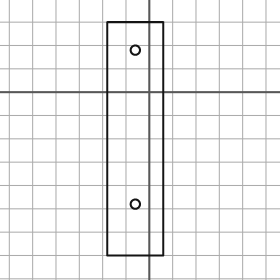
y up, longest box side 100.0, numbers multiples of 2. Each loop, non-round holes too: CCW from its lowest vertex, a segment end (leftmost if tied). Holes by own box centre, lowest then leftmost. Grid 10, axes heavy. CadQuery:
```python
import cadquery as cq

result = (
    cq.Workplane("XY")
    .moveTo(-18.0, -70.0)
    .lineTo(6.0, -70.0)
    .lineTo(6.0, 30.0)
    .lineTo(-18.0, 30.0)
    .close()
    .moveTo(-6.0, -48.0)
    .circle(2.0)
    .moveTo(-6.0, 18.0)
    .circle(2.0)
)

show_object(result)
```